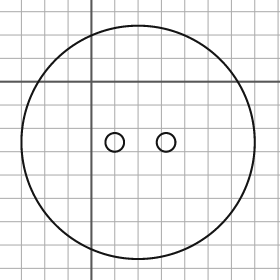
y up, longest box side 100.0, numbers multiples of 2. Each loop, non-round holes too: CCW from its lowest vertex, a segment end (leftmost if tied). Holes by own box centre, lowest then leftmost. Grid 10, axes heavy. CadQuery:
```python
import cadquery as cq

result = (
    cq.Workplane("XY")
    .moveTo(20.0, -26.0)
    .circle(50.0)
    .moveTo(10.0, -26.0)
    .circle(4.0)
    .moveTo(32.0, -26.0)
    .circle(4.0)
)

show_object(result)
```